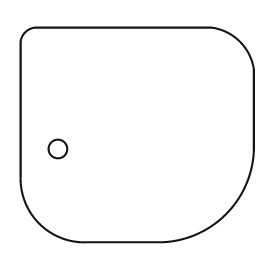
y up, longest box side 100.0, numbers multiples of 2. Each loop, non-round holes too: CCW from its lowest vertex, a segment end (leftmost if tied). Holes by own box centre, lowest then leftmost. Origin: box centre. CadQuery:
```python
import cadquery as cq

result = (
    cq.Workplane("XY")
    .moveTo(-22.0, -46.0)
    .lineTo(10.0, -46.0)
    .threePointArc((38.0, -34.0), (50.0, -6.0))
    .lineTo(50.0, 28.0)
    .threePointArc((44.0, 40.0), (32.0, 46.0))
    .lineTo(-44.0, 46.0)
    .threePointArc((-48.0, 44.0), (-50.0, 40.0))
    .lineTo(-50.0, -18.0)
    .threePointArc((-42.0, -38.0), (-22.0, -46.0))
    .close()
    .moveTo(-34.0, -6.0)
    .circle(4.0)
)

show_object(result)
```